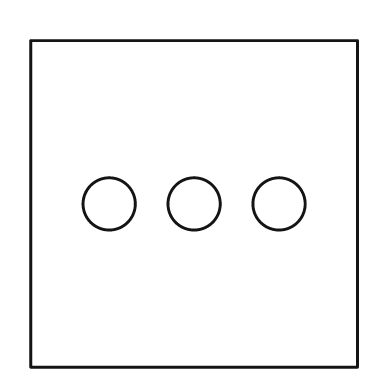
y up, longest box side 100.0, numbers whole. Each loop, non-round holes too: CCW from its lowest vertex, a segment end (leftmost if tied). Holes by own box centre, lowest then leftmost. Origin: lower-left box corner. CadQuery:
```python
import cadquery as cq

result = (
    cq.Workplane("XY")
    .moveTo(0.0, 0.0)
    .lineTo(100.0, 0.0)
    .lineTo(100.0, 100.0)
    .lineTo(0.0, 100.0)
    .close()
    .moveTo(24.0, 50.0)
    .circle(8.0)
    .moveTo(50.0, 50.0)
    .circle(8.0)
    .moveTo(76.0, 50.0)
    .circle(8.0)
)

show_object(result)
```